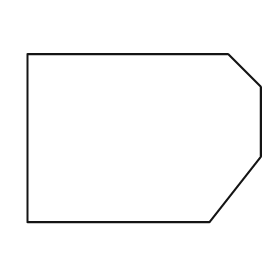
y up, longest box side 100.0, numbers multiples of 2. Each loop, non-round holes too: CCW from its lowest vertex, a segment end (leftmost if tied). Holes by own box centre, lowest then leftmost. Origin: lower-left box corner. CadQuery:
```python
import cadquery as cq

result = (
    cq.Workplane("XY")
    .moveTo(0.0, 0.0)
    .lineTo(78.0, 0.0)
    .lineTo(100.0, 28.0)
    .lineTo(100.0, 58.0)
    .lineTo(86.0, 72.0)
    .lineTo(0.0, 72.0)
    .close()
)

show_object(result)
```